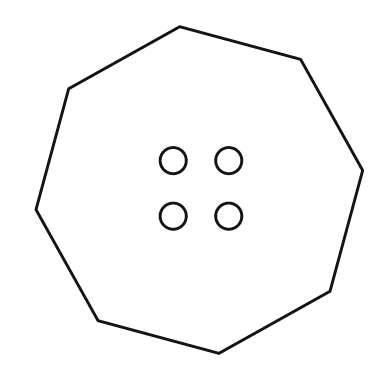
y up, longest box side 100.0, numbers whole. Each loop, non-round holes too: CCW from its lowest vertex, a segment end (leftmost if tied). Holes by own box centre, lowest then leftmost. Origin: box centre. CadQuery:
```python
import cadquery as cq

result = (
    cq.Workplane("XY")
    .moveTo(6.0, -50.0)
    .lineTo(40.0, -31.0)
    .lineTo(50.0, 6.0)
    .lineTo(31.0, 40.0)
    .lineTo(-6.0, 50.0)
    .lineTo(-40.0, 31.0)
    .lineTo(-50.0, -6.0)
    .lineTo(-31.0, -40.0)
    .close()
    .moveTo(-8.0, -8.0)
    .circle(4.0)
    .moveTo(9.0, -8.0)
    .circle(4.0)
    .moveTo(-8.0, 9.0)
    .circle(4.0)
    .moveTo(9.0, 9.0)
    .circle(4.0)
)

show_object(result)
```